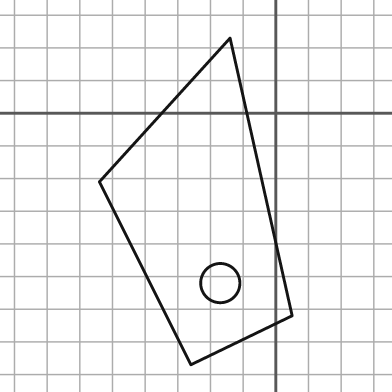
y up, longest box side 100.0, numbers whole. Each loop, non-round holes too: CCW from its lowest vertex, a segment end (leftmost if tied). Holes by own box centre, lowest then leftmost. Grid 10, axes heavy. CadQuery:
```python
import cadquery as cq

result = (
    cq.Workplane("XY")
    .moveTo(-26.0, -77.0)
    .lineTo(5.0, -62.0)
    .lineTo(-14.0, 23.0)
    .lineTo(-54.0, -21.0)
    .close()
    .moveTo(-17.0, -52.0)
    .circle(6.0)
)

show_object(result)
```